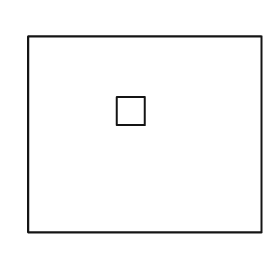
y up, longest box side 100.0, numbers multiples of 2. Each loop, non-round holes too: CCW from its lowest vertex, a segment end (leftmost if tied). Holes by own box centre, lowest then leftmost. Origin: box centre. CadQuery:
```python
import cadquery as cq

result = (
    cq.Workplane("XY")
    .moveTo(-50.0, -42.0)
    .lineTo(50.0, -42.0)
    .lineTo(50.0, 42.0)
    .lineTo(-50.0, 42.0)
    .close()
    .moveTo(-12.0, 4.0)
    .lineTo(0.0, 4.0)
    .lineTo(0.0, 16.0)
    .lineTo(-12.0, 16.0)
    .close()
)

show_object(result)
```